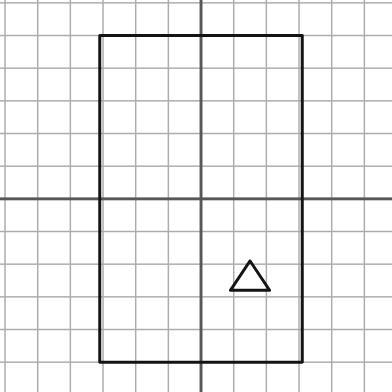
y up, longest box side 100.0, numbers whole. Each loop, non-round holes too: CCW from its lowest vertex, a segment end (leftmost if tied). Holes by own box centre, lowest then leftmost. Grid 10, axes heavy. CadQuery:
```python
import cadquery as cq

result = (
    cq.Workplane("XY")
    .moveTo(-31.0, -50.0)
    .lineTo(31.0, -50.0)
    .lineTo(31.0, 50.0)
    .lineTo(-31.0, 50.0)
    .close()
    .moveTo(9.0, -28.0)
    .lineTo(21.0, -28.0)
    .lineTo(15.0, -19.0)
    .close()
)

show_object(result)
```